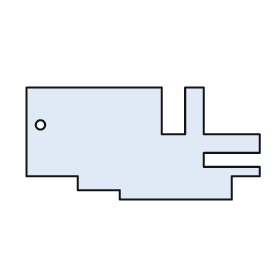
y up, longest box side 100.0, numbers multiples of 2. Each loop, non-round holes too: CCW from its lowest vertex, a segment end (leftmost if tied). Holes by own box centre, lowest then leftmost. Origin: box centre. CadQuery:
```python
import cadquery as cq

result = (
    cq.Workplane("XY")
    .moveTo(-10.0, -24.0)
    .lineTo(38.0, -24.0)
    .lineTo(38.0, -14.0)
    .lineTo(50.0, -14.0)
    .lineTo(50.0, -10.0)
    .lineTo(26.0, -10.0)
    .lineTo(26.0, -4.0)
    .lineTo(50.0, -4.0)
    .lineTo(50.0, 4.0)
    .lineTo(26.0, 4.0)
    .lineTo(26.0, 24.0)
    .lineTo(18.0, 24.0)
    .lineTo(18.0, 4.0)
    .lineTo(8.0, 4.0)
    .lineTo(8.0, 24.0)
    .lineTo(-50.0, 24.0)
    .lineTo(-50.0, -14.0)
    .lineTo(-28.0, -14.0)
    .lineTo(-28.0, -20.0)
    .lineTo(-10.0, -20.0)
    .close()
    .moveTo(-44.0, 8.0)
    .circle(2.0)
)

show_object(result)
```